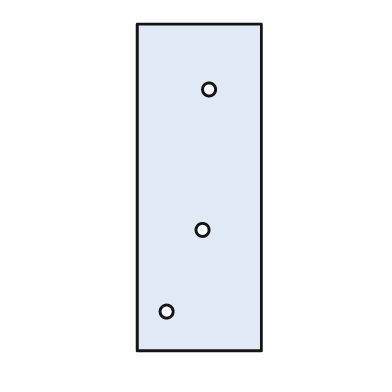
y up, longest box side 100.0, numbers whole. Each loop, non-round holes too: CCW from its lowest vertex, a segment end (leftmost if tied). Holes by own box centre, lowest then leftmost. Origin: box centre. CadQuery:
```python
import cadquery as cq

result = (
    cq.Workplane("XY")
    .moveTo(-19.0, -50.0)
    .lineTo(19.0, -50.0)
    .lineTo(19.0, 50.0)
    .lineTo(-19.0, 50.0)
    .close()
    .moveTo(-10.0, -38.0)
    .circle(2.0)
    .moveTo(1.0, -13.0)
    .circle(2.0)
    .moveTo(3.0, 30.0)
    .circle(2.0)
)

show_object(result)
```